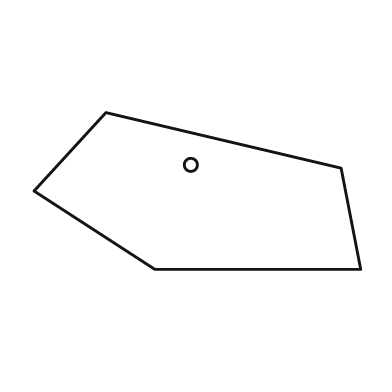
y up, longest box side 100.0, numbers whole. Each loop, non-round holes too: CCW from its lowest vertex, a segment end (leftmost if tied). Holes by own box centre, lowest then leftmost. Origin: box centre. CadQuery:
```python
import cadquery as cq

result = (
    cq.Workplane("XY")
    .moveTo(-13.0, -24.0)
    .lineTo(50.0, -24.0)
    .lineTo(44.0, 7.0)
    .lineTo(-28.0, 24.0)
    .lineTo(-50.0, 0.0)
    .close()
    .moveTo(-2.0, 8.0)
    .circle(2.0)
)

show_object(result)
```